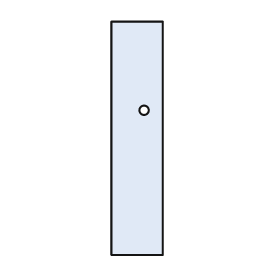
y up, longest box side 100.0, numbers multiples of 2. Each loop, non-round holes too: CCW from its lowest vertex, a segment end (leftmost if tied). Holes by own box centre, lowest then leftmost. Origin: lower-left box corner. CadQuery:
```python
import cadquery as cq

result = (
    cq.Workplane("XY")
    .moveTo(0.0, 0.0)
    .lineTo(22.0, 0.0)
    .lineTo(22.0, 100.0)
    .lineTo(0.0, 100.0)
    .close()
    .moveTo(14.0, 62.0)
    .circle(2.0)
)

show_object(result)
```